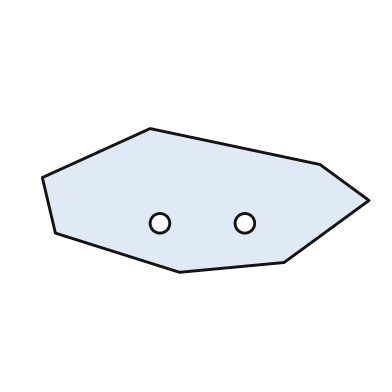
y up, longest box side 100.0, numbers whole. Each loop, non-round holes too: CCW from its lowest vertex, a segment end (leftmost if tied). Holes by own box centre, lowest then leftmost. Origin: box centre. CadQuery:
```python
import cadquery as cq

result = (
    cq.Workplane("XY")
    .moveTo(-8.0, -22.0)
    .lineTo(24.0, -19.0)
    .lineTo(50.0, 0.0)
    .lineTo(35.0, 11.0)
    .lineTo(-17.0, 22.0)
    .lineTo(-50.0, 7.0)
    .lineTo(-46.0, -10.0)
    .close()
    .moveTo(-14.0, -7.0)
    .circle(3.0)
    .moveTo(12.0, -7.0)
    .circle(3.0)
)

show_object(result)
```